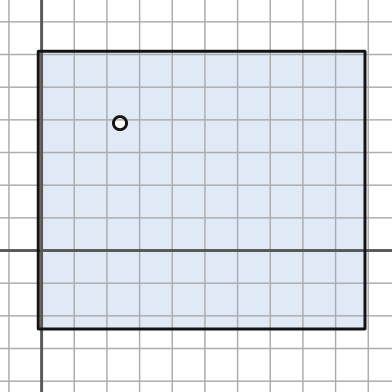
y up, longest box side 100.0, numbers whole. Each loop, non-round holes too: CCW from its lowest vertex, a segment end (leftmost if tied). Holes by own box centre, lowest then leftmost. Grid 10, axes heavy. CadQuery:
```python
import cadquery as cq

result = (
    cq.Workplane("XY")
    .moveTo(-1.0, -24.0)
    .lineTo(99.0, -24.0)
    .lineTo(99.0, 61.0)
    .lineTo(-1.0, 61.0)
    .close()
    .moveTo(24.0, 39.0)
    .circle(2.0)
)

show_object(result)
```